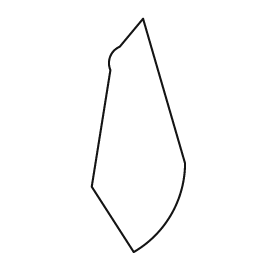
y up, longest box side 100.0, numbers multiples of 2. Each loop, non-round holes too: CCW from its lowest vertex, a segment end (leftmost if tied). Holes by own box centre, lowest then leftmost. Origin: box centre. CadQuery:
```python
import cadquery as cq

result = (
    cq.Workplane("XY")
    .moveTo(-2.0, -50.0)
    .threePointArc((14.0, -34.0), (20.0, -12.0))
    .lineTo(2.0, 50.0)
    .lineTo(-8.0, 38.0)
    .threePointArc((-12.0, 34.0), (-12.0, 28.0))
    .lineTo(-20.0, -22.0)
    .close()
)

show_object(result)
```